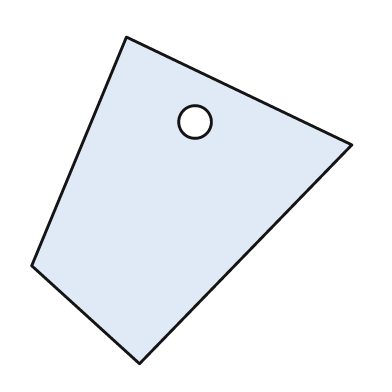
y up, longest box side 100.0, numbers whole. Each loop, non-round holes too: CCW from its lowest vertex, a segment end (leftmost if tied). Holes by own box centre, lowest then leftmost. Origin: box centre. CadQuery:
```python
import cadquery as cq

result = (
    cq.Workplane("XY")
    .moveTo(-16.0, -50.0)
    .lineTo(49.0, 17.0)
    .lineTo(-20.0, 50.0)
    .lineTo(-49.0, -20.0)
    .close()
    .moveTo(1.0, 24.0)
    .circle(5.0)
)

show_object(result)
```